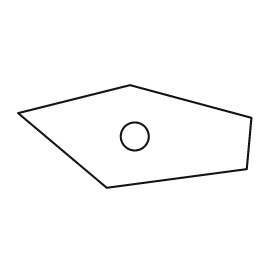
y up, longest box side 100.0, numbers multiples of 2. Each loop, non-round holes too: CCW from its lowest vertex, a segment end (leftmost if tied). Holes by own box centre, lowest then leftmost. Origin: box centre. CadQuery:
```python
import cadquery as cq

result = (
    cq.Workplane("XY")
    .moveTo(-12.0, -22.0)
    .lineTo(48.0, -14.0)
    .lineTo(50.0, 8.0)
    .lineTo(-2.0, 22.0)
    .lineTo(-50.0, 10.0)
    .close()
    .moveTo(0.0, 0.0)
    .circle(6.0)
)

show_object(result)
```